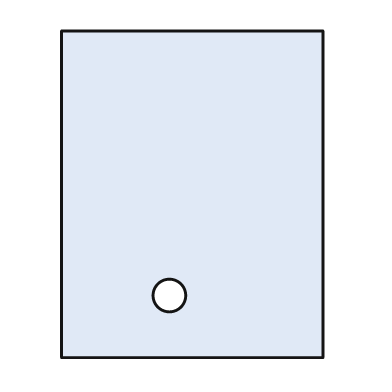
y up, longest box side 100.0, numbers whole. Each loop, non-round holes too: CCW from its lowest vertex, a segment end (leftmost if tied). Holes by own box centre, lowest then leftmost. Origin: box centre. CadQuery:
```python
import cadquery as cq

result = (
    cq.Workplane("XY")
    .moveTo(-40.0, -50.0)
    .lineTo(40.0, -50.0)
    .lineTo(40.0, 50.0)
    .lineTo(-40.0, 50.0)
    .close()
    .moveTo(-7.0, -31.0)
    .circle(5.0)
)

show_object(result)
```